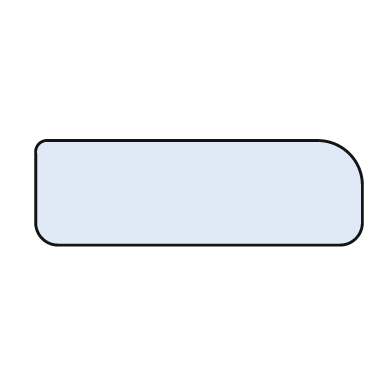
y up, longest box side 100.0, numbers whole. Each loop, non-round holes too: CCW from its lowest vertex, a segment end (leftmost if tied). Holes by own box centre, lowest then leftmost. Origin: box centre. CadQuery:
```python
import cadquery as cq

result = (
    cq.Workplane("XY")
    .moveTo(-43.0, -16.0)
    .lineTo(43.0, -16.0)
    .threePointArc((48.0, -14.0), (50.0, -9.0))
    .lineTo(50.0, 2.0)
    .threePointArc((46.0, 12.0), (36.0, 16.0))
    .lineTo(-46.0, 16.0)
    .threePointArc((-49.0, 15.0), (-50.0, 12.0))
    .lineTo(-50.0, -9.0)
    .threePointArc((-48.0, -14.0), (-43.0, -16.0))
    .close()
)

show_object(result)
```